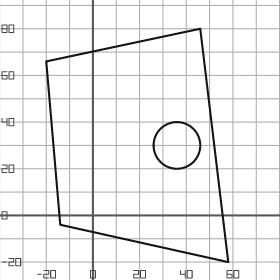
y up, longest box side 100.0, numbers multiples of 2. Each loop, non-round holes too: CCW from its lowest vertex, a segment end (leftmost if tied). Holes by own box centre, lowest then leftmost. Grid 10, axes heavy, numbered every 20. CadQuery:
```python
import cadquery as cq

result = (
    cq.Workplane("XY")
    .moveTo(58.0, -20.0)
    .lineTo(46.0, 80.0)
    .lineTo(-20.0, 66.0)
    .lineTo(-14.0, -4.0)
    .close()
    .moveTo(36.0, 30.0)
    .circle(10.0)
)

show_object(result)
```